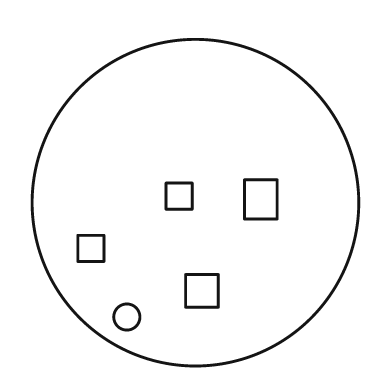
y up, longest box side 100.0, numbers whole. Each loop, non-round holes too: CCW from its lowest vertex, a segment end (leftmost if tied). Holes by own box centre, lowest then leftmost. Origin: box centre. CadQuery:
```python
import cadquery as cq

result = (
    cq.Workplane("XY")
    .moveTo(0.0, 0.0)
    .circle(50.0)
    .moveTo(-21.0, -35.0)
    .circle(4.0)
    .moveTo(-3.0, -32.0)
    .lineTo(7.0, -32.0)
    .lineTo(7.0, -22.0)
    .lineTo(-3.0, -22.0)
    .close()
    .moveTo(-36.0, -18.0)
    .lineTo(-28.0, -18.0)
    .lineTo(-28.0, -10.0)
    .lineTo(-36.0, -10.0)
    .close()
    .moveTo(15.0, -5.0)
    .lineTo(25.0, -5.0)
    .lineTo(25.0, 7.0)
    .lineTo(15.0, 7.0)
    .close()
    .moveTo(-9.0, -2.0)
    .lineTo(-1.0, -2.0)
    .lineTo(-1.0, 6.0)
    .lineTo(-9.0, 6.0)
    .close()
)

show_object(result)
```